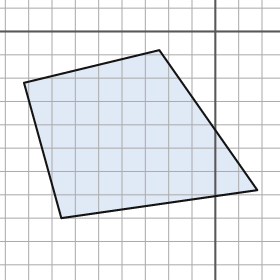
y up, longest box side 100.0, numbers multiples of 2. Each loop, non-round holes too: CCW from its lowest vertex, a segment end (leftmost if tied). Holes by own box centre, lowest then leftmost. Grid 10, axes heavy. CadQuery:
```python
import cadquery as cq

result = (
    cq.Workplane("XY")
    .moveTo(-66.0, -80.0)
    .lineTo(18.0, -68.0)
    .lineTo(-24.0, -8.0)
    .lineTo(-82.0, -22.0)
    .close()
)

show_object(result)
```